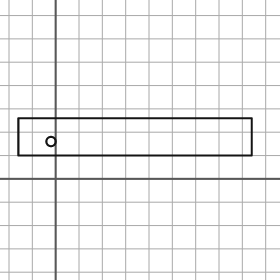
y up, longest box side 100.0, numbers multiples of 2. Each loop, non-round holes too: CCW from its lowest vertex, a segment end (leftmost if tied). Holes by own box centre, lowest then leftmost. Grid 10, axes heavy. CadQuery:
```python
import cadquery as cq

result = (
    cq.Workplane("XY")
    .moveTo(-16.0, 10.0)
    .lineTo(84.0, 10.0)
    .lineTo(84.0, 26.0)
    .lineTo(-16.0, 26.0)
    .close()
    .moveTo(-2.0, 16.0)
    .circle(2.0)
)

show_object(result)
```